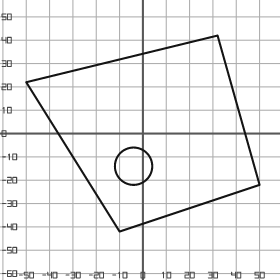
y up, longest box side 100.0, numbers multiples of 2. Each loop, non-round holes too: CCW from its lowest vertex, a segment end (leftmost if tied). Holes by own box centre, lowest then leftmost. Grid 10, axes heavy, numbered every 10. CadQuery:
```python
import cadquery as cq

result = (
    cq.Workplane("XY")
    .moveTo(-10.0, -42.0)
    .lineTo(50.0, -22.0)
    .lineTo(32.0, 42.0)
    .lineTo(-50.0, 22.0)
    .close()
    .moveTo(-4.0, -14.0)
    .circle(8.0)
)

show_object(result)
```